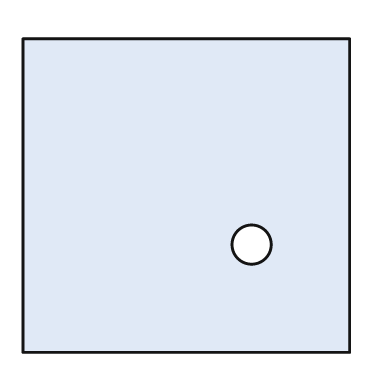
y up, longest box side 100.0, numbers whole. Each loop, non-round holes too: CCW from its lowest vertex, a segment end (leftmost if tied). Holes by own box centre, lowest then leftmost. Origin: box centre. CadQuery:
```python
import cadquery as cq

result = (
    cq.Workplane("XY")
    .moveTo(-50.0, -48.0)
    .lineTo(50.0, -48.0)
    .lineTo(50.0, 48.0)
    .lineTo(-50.0, 48.0)
    .close()
    .moveTo(20.0, -15.0)
    .circle(6.0)
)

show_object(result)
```